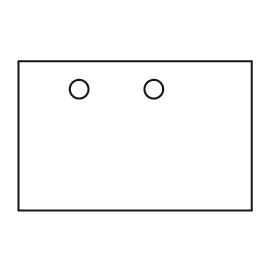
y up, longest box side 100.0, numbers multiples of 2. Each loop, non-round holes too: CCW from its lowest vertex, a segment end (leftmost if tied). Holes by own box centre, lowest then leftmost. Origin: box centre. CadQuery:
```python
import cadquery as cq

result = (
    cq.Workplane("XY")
    .moveTo(-50.0, -32.0)
    .lineTo(50.0, -32.0)
    .lineTo(50.0, 32.0)
    .lineTo(-50.0, 32.0)
    .close()
    .moveTo(-24.0, 20.0)
    .circle(4.0)
    .moveTo(8.0, 20.0)
    .circle(4.0)
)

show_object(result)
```